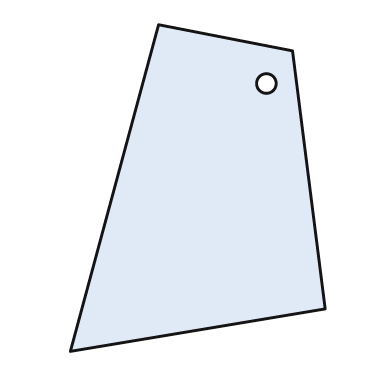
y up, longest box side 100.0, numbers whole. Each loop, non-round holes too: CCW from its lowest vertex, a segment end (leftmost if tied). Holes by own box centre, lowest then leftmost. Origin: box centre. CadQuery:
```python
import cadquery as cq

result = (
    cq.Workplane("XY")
    .moveTo(-39.0, -50.0)
    .lineTo(39.0, -37.0)
    .lineTo(29.0, 42.0)
    .lineTo(-12.0, 50.0)
    .close()
    .moveTo(21.0, 32.0)
    .circle(3.0)
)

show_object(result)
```